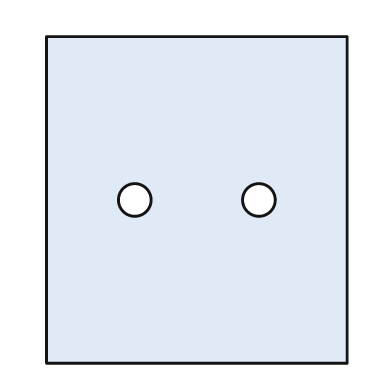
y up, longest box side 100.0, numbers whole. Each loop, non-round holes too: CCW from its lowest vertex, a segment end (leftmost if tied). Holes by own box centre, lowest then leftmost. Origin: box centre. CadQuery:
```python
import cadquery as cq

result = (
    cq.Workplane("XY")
    .moveTo(-46.0, -50.0)
    .lineTo(46.0, -50.0)
    .lineTo(46.0, 50.0)
    .lineTo(-46.0, 50.0)
    .close()
    .moveTo(-19.0, 0.0)
    .circle(5.0)
    .moveTo(19.0, 0.0)
    .circle(5.0)
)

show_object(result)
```